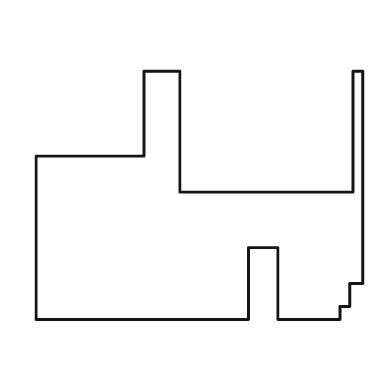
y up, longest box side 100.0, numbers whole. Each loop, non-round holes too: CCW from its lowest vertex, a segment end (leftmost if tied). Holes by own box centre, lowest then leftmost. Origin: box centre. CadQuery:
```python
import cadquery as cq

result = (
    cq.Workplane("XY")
    .moveTo(-50.0, -38.0)
    .lineTo(15.0, -38.0)
    .lineTo(15.0, -16.0)
    .lineTo(24.0, -16.0)
    .lineTo(24.0, -38.0)
    .lineTo(43.0, -38.0)
    .lineTo(43.0, -34.0)
    .lineTo(46.0, -34.0)
    .lineTo(46.0, -27.0)
    .lineTo(50.0, -27.0)
    .lineTo(50.0, 38.0)
    .lineTo(47.0, 38.0)
    .lineTo(47.0, 1.0)
    .lineTo(-6.0, 1.0)
    .lineTo(-6.0, 38.0)
    .lineTo(-17.0, 38.0)
    .lineTo(-17.0, 12.0)
    .lineTo(-50.0, 12.0)
    .close()
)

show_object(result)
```